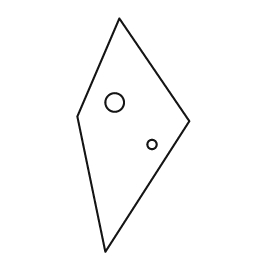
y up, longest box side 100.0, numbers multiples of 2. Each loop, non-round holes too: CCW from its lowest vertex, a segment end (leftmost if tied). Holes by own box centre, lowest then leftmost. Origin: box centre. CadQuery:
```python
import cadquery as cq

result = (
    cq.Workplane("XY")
    .moveTo(-12.0, -50.0)
    .lineTo(24.0, 6.0)
    .lineTo(-6.0, 50.0)
    .lineTo(-24.0, 8.0)
    .close()
    .moveTo(8.0, -4.0)
    .circle(2.0)
    .moveTo(-8.0, 14.0)
    .circle(4.0)
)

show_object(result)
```